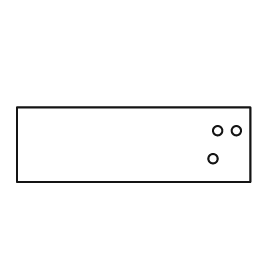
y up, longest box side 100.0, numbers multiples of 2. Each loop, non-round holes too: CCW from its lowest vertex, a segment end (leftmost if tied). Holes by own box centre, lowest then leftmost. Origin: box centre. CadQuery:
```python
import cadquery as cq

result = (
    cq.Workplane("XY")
    .moveTo(-50.0, -16.0)
    .lineTo(50.0, -16.0)
    .lineTo(50.0, 16.0)
    .lineTo(-50.0, 16.0)
    .close()
    .moveTo(34.0, -6.0)
    .circle(2.0)
    .moveTo(36.0, 6.0)
    .circle(2.0)
    .moveTo(44.0, 6.0)
    .circle(2.0)
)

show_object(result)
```